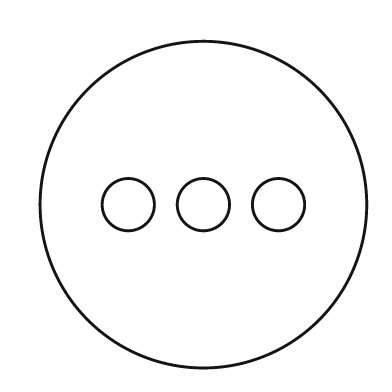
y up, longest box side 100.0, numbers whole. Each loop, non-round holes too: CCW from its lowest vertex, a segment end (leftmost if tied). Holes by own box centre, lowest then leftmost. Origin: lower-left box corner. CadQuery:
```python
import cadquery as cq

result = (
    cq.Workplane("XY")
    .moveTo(50.0, 50.0)
    .circle(50.0)
    .moveTo(27.0, 50.0)
    .circle(8.0)
    .moveTo(50.0, 50.0)
    .circle(8.0)
    .moveTo(73.0, 50.0)
    .circle(8.0)
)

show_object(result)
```